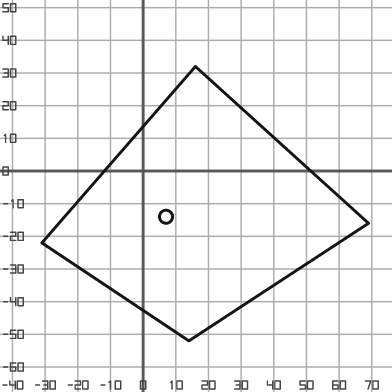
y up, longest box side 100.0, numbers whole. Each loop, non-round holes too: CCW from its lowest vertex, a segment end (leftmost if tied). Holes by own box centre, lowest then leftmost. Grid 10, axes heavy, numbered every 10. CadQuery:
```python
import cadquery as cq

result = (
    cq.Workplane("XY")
    .moveTo(14.0, -52.0)
    .lineTo(69.0, -16.0)
    .lineTo(16.0, 32.0)
    .lineTo(-31.0, -22.0)
    .close()
    .moveTo(7.0, -14.0)
    .circle(2.0)
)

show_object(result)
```